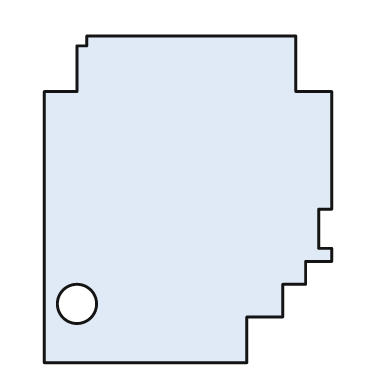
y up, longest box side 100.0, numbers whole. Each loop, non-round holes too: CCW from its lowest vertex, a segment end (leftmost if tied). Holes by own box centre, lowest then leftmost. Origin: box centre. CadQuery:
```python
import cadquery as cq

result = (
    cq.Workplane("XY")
    .moveTo(-44.0, -50.0)
    .lineTo(18.0, -50.0)
    .lineTo(18.0, -36.0)
    .lineTo(29.0, -36.0)
    .lineTo(29.0, -26.0)
    .lineTo(36.0, -26.0)
    .lineTo(36.0, -19.0)
    .lineTo(44.0, -19.0)
    .lineTo(44.0, -15.0)
    .lineTo(40.0, -15.0)
    .lineTo(40.0, -3.0)
    .lineTo(44.0, -3.0)
    .lineTo(44.0, 33.0)
    .lineTo(33.0, 33.0)
    .lineTo(33.0, 50.0)
    .lineTo(-31.0, 50.0)
    .lineTo(-31.0, 47.0)
    .lineTo(-34.0, 47.0)
    .lineTo(-34.0, 33.0)
    .lineTo(-44.0, 33.0)
    .close()
    .moveTo(-34.0, -32.0)
    .circle(6.0)
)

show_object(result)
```